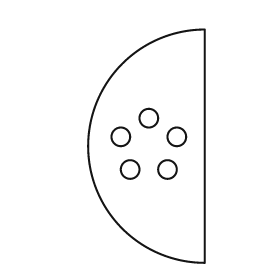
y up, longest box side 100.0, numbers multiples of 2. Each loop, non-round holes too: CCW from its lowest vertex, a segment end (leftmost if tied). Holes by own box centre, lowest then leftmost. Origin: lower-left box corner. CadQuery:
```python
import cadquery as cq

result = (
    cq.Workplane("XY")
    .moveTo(50.0, 0.0)
    .lineTo(50.0, 100.0)
    .threePointArc((0.0, 50.0), (50.0, 0.0))
    .close()
    .moveTo(18.0, 40.0)
    .circle(4.0)
    .moveTo(34.0, 40.0)
    .circle(4.0)
    .moveTo(14.0, 54.0)
    .circle(4.0)
    .moveTo(38.0, 54.0)
    .circle(4.0)
    .moveTo(26.0, 62.0)
    .circle(4.0)
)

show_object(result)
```